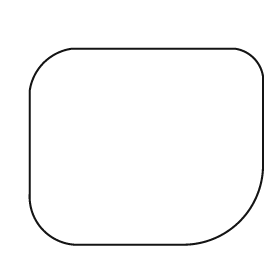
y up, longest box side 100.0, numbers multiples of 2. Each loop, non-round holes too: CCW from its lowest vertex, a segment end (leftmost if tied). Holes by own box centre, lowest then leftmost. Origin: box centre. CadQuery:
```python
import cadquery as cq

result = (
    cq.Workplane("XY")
    .moveTo(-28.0, -42.0)
    .lineTo(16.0, -42.0)
    .threePointArc((40.0, -32.0), (50.0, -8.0))
    .lineTo(50.0, 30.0)
    .threePointArc((46.0, 38.0), (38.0, 42.0))
    .lineTo(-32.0, 42.0)
    .threePointArc((-44.0, 36.0), (-50.0, 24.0))
    .lineTo(-50.0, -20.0)
    .threePointArc((-44.0, -36.0), (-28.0, -42.0))
    .close()
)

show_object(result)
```